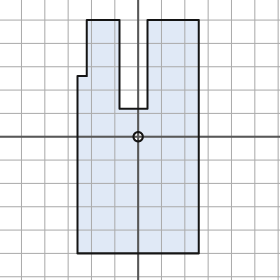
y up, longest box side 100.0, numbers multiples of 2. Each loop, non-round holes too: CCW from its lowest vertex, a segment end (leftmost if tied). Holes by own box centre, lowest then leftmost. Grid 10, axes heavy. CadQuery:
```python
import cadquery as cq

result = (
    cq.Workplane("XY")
    .moveTo(-26.0, -50.0)
    .lineTo(26.0, -50.0)
    .lineTo(26.0, 50.0)
    .lineTo(4.0, 50.0)
    .lineTo(4.0, 12.0)
    .lineTo(-8.0, 12.0)
    .lineTo(-8.0, 50.0)
    .lineTo(-22.0, 50.0)
    .lineTo(-22.0, 26.0)
    .lineTo(-26.0, 26.0)
    .close()
    .moveTo(0.0, 0.0)
    .circle(2.0)
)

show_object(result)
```